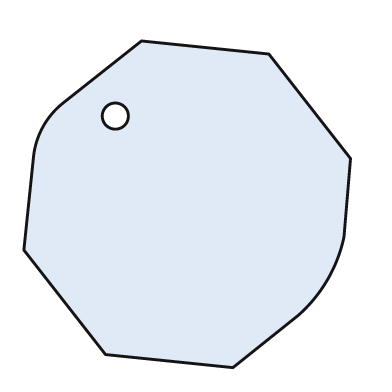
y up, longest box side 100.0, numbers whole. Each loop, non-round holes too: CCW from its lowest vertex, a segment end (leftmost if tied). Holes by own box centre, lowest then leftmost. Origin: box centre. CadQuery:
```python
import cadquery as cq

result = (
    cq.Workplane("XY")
    .moveTo(14.0, -50.0)
    .lineTo(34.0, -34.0)
    .threePointArc((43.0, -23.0), (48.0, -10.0))
    .lineTo(50.0, 14.0)
    .lineTo(25.0, 46.0)
    .lineTo(-14.0, 50.0)
    .lineTo(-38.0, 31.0)
    .threePointArc((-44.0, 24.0), (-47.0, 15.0))
    .lineTo(-50.0, -14.0)
    .lineTo(-25.0, -46.0)
    .close()
    .moveTo(-22.0, 27.0)
    .circle(4.0)
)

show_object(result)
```